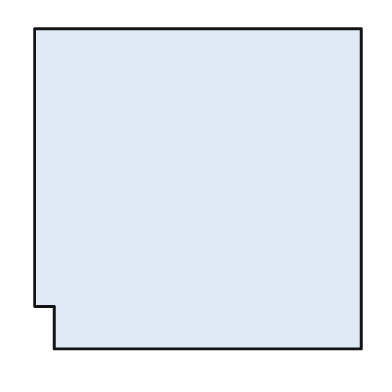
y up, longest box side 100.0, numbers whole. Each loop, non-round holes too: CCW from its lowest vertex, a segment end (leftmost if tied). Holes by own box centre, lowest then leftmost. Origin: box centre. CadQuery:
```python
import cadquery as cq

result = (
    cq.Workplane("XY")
    .moveTo(-44.0, -49.0)
    .lineTo(50.0, -49.0)
    .lineTo(50.0, 49.0)
    .lineTo(-50.0, 49.0)
    .lineTo(-50.0, -36.0)
    .lineTo(-44.0, -36.0)
    .close()
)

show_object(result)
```